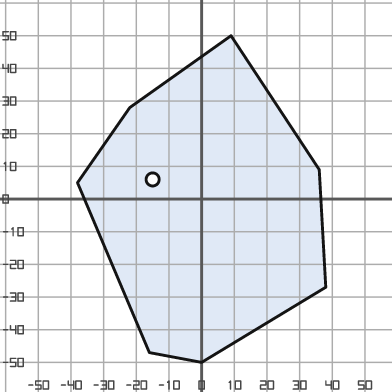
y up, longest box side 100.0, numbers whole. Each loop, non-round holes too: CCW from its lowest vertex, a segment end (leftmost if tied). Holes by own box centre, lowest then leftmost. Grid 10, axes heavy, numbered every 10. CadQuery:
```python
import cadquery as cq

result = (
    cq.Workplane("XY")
    .moveTo(0.0, -50.0)
    .lineTo(38.0, -27.0)
    .lineTo(36.0, 9.0)
    .lineTo(9.0, 50.0)
    .lineTo(-22.0, 28.0)
    .lineTo(-38.0, 5.0)
    .lineTo(-16.0, -47.0)
    .close()
    .moveTo(-15.0, 6.0)
    .circle(2.0)
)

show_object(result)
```